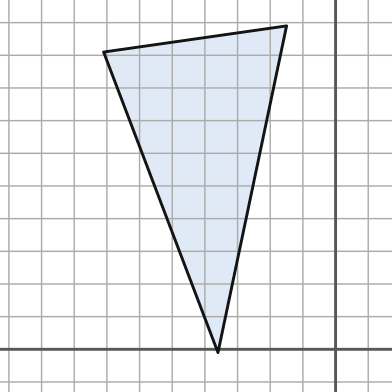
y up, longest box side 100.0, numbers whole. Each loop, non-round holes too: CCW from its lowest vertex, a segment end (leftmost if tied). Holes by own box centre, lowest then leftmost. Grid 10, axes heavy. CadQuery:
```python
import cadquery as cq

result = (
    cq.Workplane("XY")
    .moveTo(-36.0, -1.0)
    .lineTo(-15.0, 99.0)
    .lineTo(-71.0, 91.0)
    .close()
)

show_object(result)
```